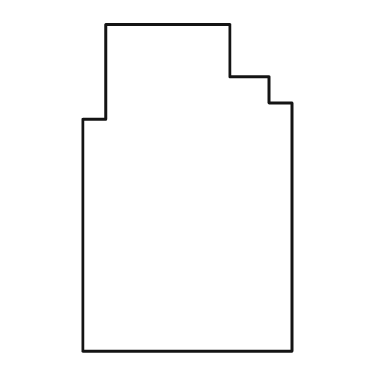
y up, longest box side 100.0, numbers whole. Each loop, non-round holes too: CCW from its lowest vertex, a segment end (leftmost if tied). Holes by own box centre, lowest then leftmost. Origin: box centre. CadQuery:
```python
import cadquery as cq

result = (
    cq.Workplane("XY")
    .moveTo(-32.0, -50.0)
    .lineTo(32.0, -50.0)
    .lineTo(32.0, 26.0)
    .lineTo(25.0, 26.0)
    .lineTo(25.0, 34.0)
    .lineTo(13.0, 34.0)
    .lineTo(13.0, 50.0)
    .lineTo(-25.0, 50.0)
    .lineTo(-25.0, 21.0)
    .lineTo(-32.0, 21.0)
    .close()
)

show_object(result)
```